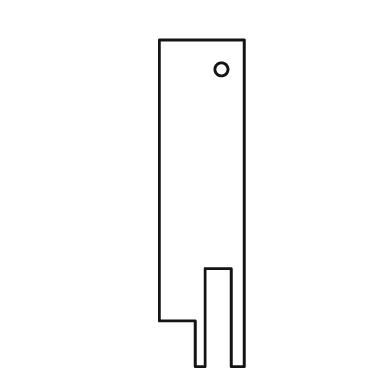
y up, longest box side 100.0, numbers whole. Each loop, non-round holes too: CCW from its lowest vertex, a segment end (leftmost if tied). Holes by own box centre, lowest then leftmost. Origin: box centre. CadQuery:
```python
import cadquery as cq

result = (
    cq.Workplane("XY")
    .moveTo(-2.0, -50.0)
    .lineTo(1.0, -50.0)
    .lineTo(1.0, -20.0)
    .lineTo(9.0, -20.0)
    .lineTo(9.0, -50.0)
    .lineTo(13.0, -50.0)
    .lineTo(13.0, 50.0)
    .lineTo(-13.0, 50.0)
    .lineTo(-13.0, -36.0)
    .lineTo(-2.0, -36.0)
    .close()
    .moveTo(6.0, 41.0)
    .circle(2.0)
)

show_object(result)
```